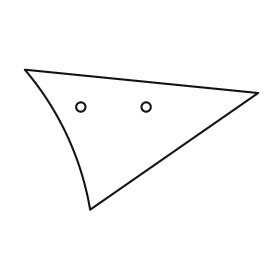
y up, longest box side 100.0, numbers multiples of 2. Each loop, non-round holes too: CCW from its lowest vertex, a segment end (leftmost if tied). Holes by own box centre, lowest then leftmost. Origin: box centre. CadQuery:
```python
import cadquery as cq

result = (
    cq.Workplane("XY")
    .moveTo(-22.0, -30.0)
    .lineTo(50.0, 20.0)
    .lineTo(-50.0, 30.0)
    .threePointArc((-32.0, 2.0), (-22.0, -30.0))
    .close()
    .moveTo(-26.0, 14.0)
    .circle(2.0)
    .moveTo(2.0, 14.0)
    .circle(2.0)
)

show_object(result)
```